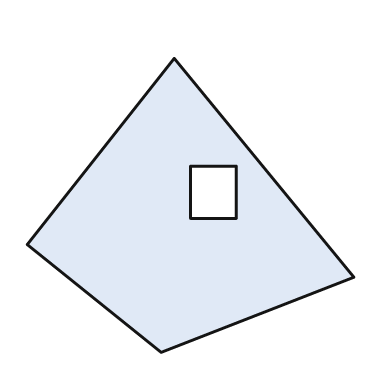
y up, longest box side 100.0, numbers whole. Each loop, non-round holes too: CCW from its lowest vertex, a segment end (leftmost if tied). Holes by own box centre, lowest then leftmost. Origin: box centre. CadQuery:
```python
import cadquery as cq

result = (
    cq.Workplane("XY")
    .moveTo(-9.0, -45.0)
    .lineTo(50.0, -22.0)
    .lineTo(-5.0, 45.0)
    .lineTo(-50.0, -12.0)
    .close()
    .moveTo(0.0, -4.0)
    .lineTo(14.0, -4.0)
    .lineTo(14.0, 12.0)
    .lineTo(0.0, 12.0)
    .close()
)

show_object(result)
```